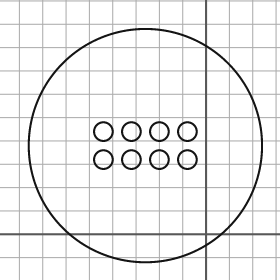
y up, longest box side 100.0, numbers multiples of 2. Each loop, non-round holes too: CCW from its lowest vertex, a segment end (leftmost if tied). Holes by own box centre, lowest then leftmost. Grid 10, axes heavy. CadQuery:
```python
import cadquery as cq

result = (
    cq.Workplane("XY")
    .moveTo(-26.0, 38.0)
    .circle(50.0)
    .moveTo(-44.0, 32.0)
    .circle(4.0)
    .moveTo(-32.0, 32.0)
    .circle(4.0)
    .moveTo(-20.0, 32.0)
    .circle(4.0)
    .moveTo(-8.0, 32.0)
    .circle(4.0)
    .moveTo(-44.0, 44.0)
    .circle(4.0)
    .moveTo(-32.0, 44.0)
    .circle(4.0)
    .moveTo(-20.0, 44.0)
    .circle(4.0)
    .moveTo(-8.0, 44.0)
    .circle(4.0)
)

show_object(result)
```